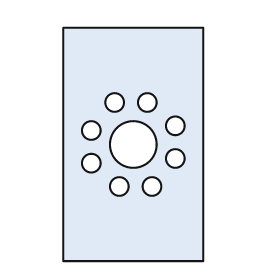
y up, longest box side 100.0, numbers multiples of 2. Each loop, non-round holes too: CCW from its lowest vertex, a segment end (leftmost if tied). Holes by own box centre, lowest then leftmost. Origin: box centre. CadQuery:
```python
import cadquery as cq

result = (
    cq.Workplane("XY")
    .moveTo(-30.0, -50.0)
    .lineTo(30.0, -50.0)
    .lineTo(30.0, 50.0)
    .lineTo(-30.0, 50.0)
    .close()
    .moveTo(-6.0, -18.0)
    .circle(4.0)
    .moveTo(8.0, -18.0)
    .circle(4.0)
    .moveTo(-18.0, -8.0)
    .circle(4.0)
    .moveTo(18.0, -6.0)
    .circle(4.0)
    .moveTo(0.0, 0.0)
    .circle(10.0)
    .moveTo(-18.0, 6.0)
    .circle(4.0)
    .moveTo(18.0, 8.0)
    .circle(4.0)
    .moveTo(-8.0, 18.0)
    .circle(4.0)
    .moveTo(6.0, 18.0)
    .circle(4.0)
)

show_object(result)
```